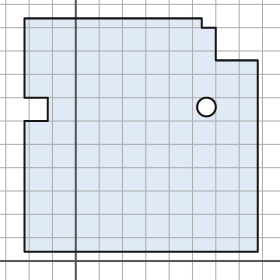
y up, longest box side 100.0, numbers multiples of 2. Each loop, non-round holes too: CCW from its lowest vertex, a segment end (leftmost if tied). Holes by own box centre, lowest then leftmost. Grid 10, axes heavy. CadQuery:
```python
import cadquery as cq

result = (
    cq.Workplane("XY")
    .moveTo(-22.0, 4.0)
    .lineTo(78.0, 4.0)
    .lineTo(78.0, 86.0)
    .lineTo(60.0, 86.0)
    .lineTo(60.0, 100.0)
    .lineTo(54.0, 100.0)
    .lineTo(54.0, 104.0)
    .lineTo(-22.0, 104.0)
    .lineTo(-22.0, 70.0)
    .lineTo(-12.0, 70.0)
    .lineTo(-12.0, 60.0)
    .lineTo(-22.0, 60.0)
    .close()
    .moveTo(56.0, 66.0)
    .circle(4.0)
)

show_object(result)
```